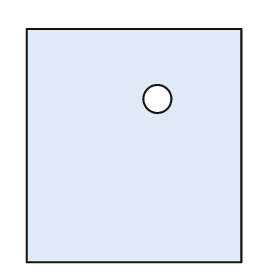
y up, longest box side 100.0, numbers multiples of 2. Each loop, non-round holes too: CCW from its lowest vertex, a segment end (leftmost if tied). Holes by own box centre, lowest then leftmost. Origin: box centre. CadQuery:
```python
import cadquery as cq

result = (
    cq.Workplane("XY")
    .moveTo(-46.0, -50.0)
    .lineTo(46.0, -50.0)
    .lineTo(46.0, 50.0)
    .lineTo(-46.0, 50.0)
    .close()
    .moveTo(10.0, 20.0)
    .circle(6.0)
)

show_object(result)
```